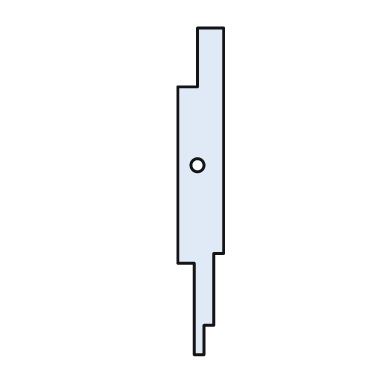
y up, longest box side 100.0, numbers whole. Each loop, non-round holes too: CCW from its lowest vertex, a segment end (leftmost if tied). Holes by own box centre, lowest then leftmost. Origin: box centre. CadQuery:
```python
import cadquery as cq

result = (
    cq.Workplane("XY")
    .moveTo(-2.0, -50.0)
    .lineTo(1.0, -50.0)
    .lineTo(1.0, -41.0)
    .lineTo(4.0, -41.0)
    .lineTo(4.0, -19.0)
    .lineTo(7.0, -19.0)
    .lineTo(7.0, 50.0)
    .lineTo(-1.0, 50.0)
    .lineTo(-1.0, 32.0)
    .lineTo(-7.0, 32.0)
    .lineTo(-7.0, -22.0)
    .lineTo(-2.0, -22.0)
    .close()
    .moveTo(-1.0, 8.0)
    .circle(2.0)
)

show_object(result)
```